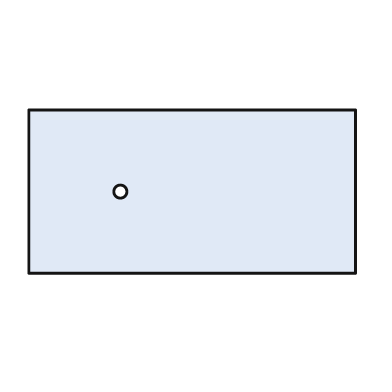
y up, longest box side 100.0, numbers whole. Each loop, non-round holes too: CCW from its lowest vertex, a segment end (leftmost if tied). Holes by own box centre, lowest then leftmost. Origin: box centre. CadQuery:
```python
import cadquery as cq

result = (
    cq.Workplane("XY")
    .moveTo(-50.0, -25.0)
    .lineTo(50.0, -25.0)
    .lineTo(50.0, 25.0)
    .lineTo(-50.0, 25.0)
    .close()
    .moveTo(-22.0, 0.0)
    .circle(2.0)
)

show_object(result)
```